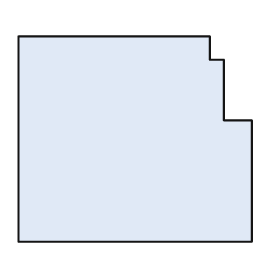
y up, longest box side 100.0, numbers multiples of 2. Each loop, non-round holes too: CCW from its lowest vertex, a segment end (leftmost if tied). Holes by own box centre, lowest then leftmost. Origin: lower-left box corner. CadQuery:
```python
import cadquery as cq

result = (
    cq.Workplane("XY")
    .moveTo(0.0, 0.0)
    .lineTo(100.0, 0.0)
    .lineTo(100.0, 52.0)
    .lineTo(88.0, 52.0)
    .lineTo(88.0, 78.0)
    .lineTo(82.0, 78.0)
    .lineTo(82.0, 88.0)
    .lineTo(0.0, 88.0)
    .close()
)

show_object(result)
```